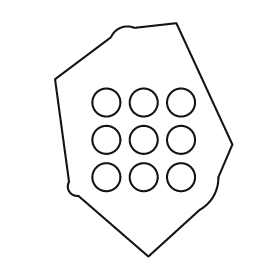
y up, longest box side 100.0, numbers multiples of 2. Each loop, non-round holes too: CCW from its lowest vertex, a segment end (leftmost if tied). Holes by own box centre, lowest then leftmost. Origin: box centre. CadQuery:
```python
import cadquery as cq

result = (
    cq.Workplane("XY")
    .moveTo(2.0, -50.0)
    .lineTo(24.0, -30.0)
    .threePointArc((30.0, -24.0), (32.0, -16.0))
    .lineTo(38.0, -2.0)
    .lineTo(14.0, 50.0)
    .lineTo(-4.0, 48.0)
    .threePointArc((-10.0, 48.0), (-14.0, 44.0))
    .lineTo(-38.0, 26.0)
    .lineTo(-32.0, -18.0)
    .threePointArc((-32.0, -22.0), (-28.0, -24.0))
    .close()
    .moveTo(-16.0, -16.0)
    .circle(6.0)
    .moveTo(0.0, -16.0)
    .circle(6.0)
    .moveTo(16.0, -16.0)
    .circle(6.0)
    .moveTo(-16.0, 0.0)
    .circle(6.0)
    .moveTo(0.0, 0.0)
    .circle(6.0)
    .moveTo(16.0, 0.0)
    .circle(6.0)
    .moveTo(-16.0, 16.0)
    .circle(6.0)
    .moveTo(0.0, 16.0)
    .circle(6.0)
    .moveTo(16.0, 16.0)
    .circle(6.0)
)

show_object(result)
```